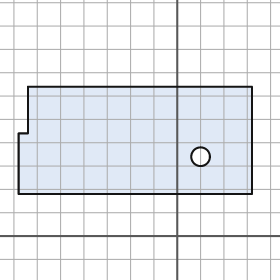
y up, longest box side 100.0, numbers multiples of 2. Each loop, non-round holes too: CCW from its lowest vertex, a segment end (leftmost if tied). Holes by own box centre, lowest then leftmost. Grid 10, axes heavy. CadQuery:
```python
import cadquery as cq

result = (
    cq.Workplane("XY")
    .moveTo(-68.0, 18.0)
    .lineTo(32.0, 18.0)
    .lineTo(32.0, 64.0)
    .lineTo(-64.0, 64.0)
    .lineTo(-64.0, 44.0)
    .lineTo(-68.0, 44.0)
    .close()
    .moveTo(10.0, 34.0)
    .circle(4.0)
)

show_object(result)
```